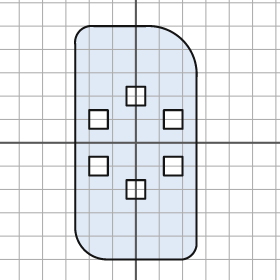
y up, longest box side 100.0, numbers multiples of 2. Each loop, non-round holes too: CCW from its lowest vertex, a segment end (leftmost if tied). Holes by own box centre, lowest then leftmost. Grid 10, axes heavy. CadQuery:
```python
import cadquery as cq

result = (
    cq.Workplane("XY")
    .moveTo(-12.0, -50.0)
    .lineTo(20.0, -50.0)
    .threePointArc((24.0, -48.0), (26.0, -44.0))
    .lineTo(26.0, 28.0)
    .threePointArc((20.0, 44.0), (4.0, 50.0))
    .lineTo(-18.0, 50.0)
    .threePointArc((-24.0, 48.0), (-26.0, 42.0))
    .lineTo(-26.0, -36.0)
    .threePointArc((-22.0, -46.0), (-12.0, -50.0))
    .close()
    .moveTo(-4.0, -24.0)
    .lineTo(4.0, -24.0)
    .lineTo(4.0, -16.0)
    .lineTo(-4.0, -16.0)
    .close()
    .moveTo(-20.0, -14.0)
    .lineTo(-12.0, -14.0)
    .lineTo(-12.0, -6.0)
    .lineTo(-20.0, -6.0)
    .close()
    .moveTo(12.0, -14.0)
    .lineTo(20.0, -14.0)
    .lineTo(20.0, -6.0)
    .lineTo(12.0, -6.0)
    .close()
    .moveTo(-20.0, 6.0)
    .lineTo(-12.0, 6.0)
    .lineTo(-12.0, 14.0)
    .lineTo(-20.0, 14.0)
    .close()
    .moveTo(12.0, 6.0)
    .lineTo(20.0, 6.0)
    .lineTo(20.0, 14.0)
    .lineTo(12.0, 14.0)
    .close()
    .moveTo(-4.0, 16.0)
    .lineTo(4.0, 16.0)
    .lineTo(4.0, 24.0)
    .lineTo(-4.0, 24.0)
    .close()
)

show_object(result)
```